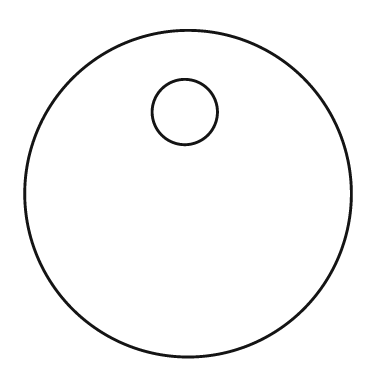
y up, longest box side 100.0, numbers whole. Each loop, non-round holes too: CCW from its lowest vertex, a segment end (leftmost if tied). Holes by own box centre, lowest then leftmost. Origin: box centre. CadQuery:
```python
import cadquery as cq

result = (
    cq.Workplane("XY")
    .moveTo(0.0, 0.0)
    .circle(50.0)
    .moveTo(-1.0, 25.0)
    .circle(10.0)
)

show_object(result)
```